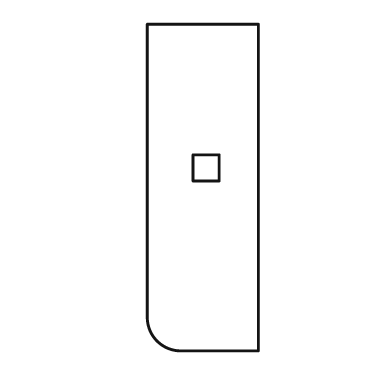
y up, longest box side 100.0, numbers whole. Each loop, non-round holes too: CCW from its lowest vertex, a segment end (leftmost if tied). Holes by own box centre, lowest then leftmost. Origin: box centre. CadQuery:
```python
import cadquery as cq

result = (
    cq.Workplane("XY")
    .moveTo(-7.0, -50.0)
    .lineTo(17.0, -50.0)
    .lineTo(17.0, 50.0)
    .lineTo(-17.0, 50.0)
    .lineTo(-17.0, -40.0)
    .threePointArc((-14.0, -47.0), (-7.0, -50.0))
    .close()
    .moveTo(-3.0, 2.0)
    .lineTo(5.0, 2.0)
    .lineTo(5.0, 10.0)
    .lineTo(-3.0, 10.0)
    .close()
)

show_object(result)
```